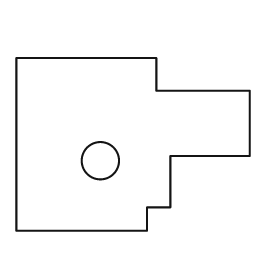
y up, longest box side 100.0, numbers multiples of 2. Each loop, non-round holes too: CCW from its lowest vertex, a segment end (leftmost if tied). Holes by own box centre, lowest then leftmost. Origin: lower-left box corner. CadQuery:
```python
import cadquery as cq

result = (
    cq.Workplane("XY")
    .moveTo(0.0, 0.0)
    .lineTo(56.0, 0.0)
    .lineTo(56.0, 10.0)
    .lineTo(66.0, 10.0)
    .lineTo(66.0, 32.0)
    .lineTo(100.0, 32.0)
    .lineTo(100.0, 60.0)
    .lineTo(60.0, 60.0)
    .lineTo(60.0, 74.0)
    .lineTo(0.0, 74.0)
    .close()
    .moveTo(36.0, 30.0)
    .circle(8.0)
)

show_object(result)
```